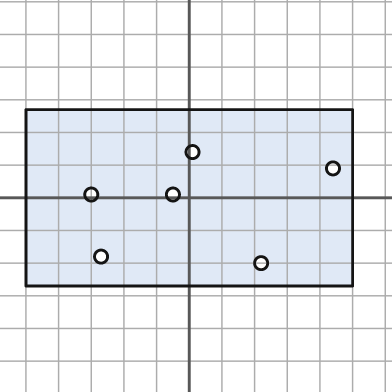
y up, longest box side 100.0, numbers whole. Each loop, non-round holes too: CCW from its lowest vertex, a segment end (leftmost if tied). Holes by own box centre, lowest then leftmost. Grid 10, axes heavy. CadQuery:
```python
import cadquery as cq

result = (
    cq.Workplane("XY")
    .moveTo(-50.0, -27.0)
    .lineTo(50.0, -27.0)
    .lineTo(50.0, 27.0)
    .lineTo(-50.0, 27.0)
    .close()
    .moveTo(22.0, -20.0)
    .circle(2.0)
    .moveTo(-27.0, -18.0)
    .circle(2.0)
    .moveTo(-30.0, 1.0)
    .circle(2.0)
    .moveTo(-5.0, 1.0)
    .circle(2.0)
    .moveTo(44.0, 9.0)
    .circle(2.0)
    .moveTo(1.0, 14.0)
    .circle(2.0)
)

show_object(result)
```